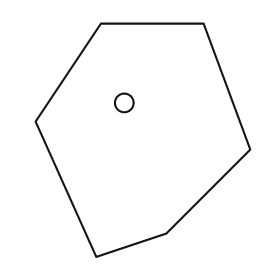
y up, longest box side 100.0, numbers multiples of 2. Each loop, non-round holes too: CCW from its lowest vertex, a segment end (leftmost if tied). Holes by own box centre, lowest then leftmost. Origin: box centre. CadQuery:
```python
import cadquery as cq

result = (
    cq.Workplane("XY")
    .moveTo(-20.0, -50.0)
    .lineTo(10.0, -40.0)
    .lineTo(46.0, -4.0)
    .lineTo(26.0, 50.0)
    .lineTo(-18.0, 50.0)
    .lineTo(-46.0, 8.0)
    .close()
    .moveTo(-8.0, 16.0)
    .circle(4.0)
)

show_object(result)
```